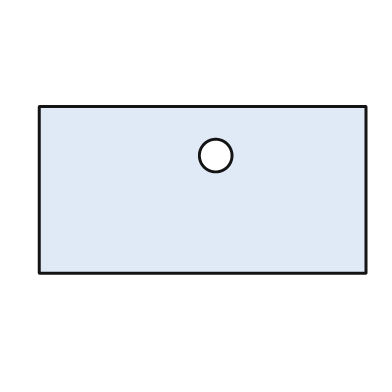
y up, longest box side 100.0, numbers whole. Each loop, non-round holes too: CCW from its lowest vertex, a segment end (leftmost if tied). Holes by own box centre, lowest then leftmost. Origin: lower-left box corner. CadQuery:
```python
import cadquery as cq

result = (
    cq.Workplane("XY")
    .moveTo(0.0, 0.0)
    .lineTo(100.0, 0.0)
    .lineTo(100.0, 51.0)
    .lineTo(0.0, 51.0)
    .close()
    .moveTo(54.0, 36.0)
    .circle(5.0)
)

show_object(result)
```